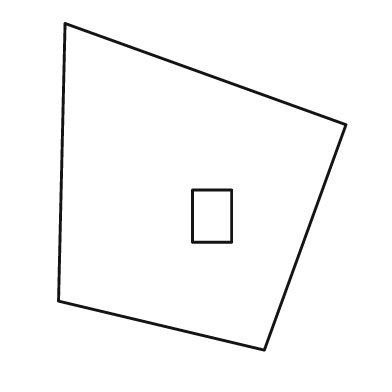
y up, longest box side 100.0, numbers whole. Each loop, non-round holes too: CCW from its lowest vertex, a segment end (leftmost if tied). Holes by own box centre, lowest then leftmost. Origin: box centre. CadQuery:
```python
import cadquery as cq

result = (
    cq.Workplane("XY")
    .moveTo(19.0, -50.0)
    .lineTo(44.0, 19.0)
    .lineTo(-42.0, 50.0)
    .lineTo(-44.0, -35.0)
    .close()
    .moveTo(-3.0, -17.0)
    .lineTo(9.0, -17.0)
    .lineTo(9.0, -1.0)
    .lineTo(-3.0, -1.0)
    .close()
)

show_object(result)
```